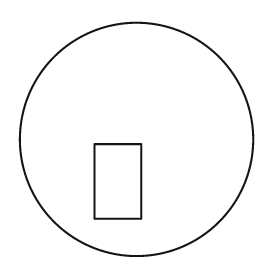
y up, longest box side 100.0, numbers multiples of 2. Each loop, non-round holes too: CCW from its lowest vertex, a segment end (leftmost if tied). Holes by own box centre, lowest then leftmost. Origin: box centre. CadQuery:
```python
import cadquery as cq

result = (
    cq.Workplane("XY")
    .moveTo(0.0, 0.0)
    .circle(50.0)
    .moveTo(-18.0, -34.0)
    .lineTo(2.0, -34.0)
    .lineTo(2.0, -2.0)
    .lineTo(-18.0, -2.0)
    .close()
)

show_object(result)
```